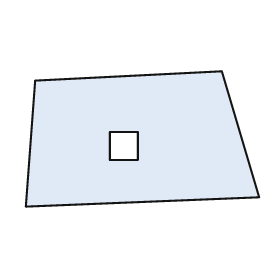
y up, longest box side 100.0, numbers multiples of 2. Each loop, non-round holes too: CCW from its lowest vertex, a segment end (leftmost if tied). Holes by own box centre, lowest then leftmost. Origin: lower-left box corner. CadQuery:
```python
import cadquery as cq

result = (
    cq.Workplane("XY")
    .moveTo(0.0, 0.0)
    .lineTo(100.0, 4.0)
    .lineTo(84.0, 58.0)
    .lineTo(4.0, 54.0)
    .close()
    .moveTo(36.0, 20.0)
    .lineTo(48.0, 20.0)
    .lineTo(48.0, 32.0)
    .lineTo(36.0, 32.0)
    .close()
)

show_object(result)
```